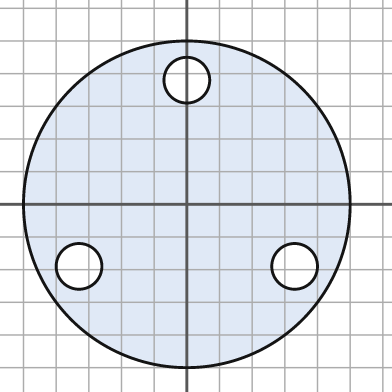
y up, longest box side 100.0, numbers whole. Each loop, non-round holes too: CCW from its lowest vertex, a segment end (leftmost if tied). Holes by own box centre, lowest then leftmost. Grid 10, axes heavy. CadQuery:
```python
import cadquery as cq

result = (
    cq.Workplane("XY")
    .moveTo(0.0, 0.0)
    .circle(50.0)
    .moveTo(-33.0, -19.0)
    .circle(7.0)
    .moveTo(33.0, -19.0)
    .circle(7.0)
    .moveTo(0.0, 38.0)
    .circle(7.0)
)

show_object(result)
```